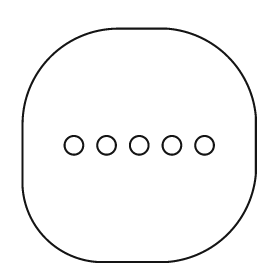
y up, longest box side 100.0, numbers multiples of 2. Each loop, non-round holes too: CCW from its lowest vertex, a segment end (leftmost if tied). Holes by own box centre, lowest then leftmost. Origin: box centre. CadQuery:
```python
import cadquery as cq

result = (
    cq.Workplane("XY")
    .moveTo(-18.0, -50.0)
    .lineTo(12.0, -50.0)
    .threePointArc((38.0, -38.0), (50.0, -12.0))
    .lineTo(50.0, 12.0)
    .threePointArc((38.0, 38.0), (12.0, 50.0))
    .lineTo(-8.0, 50.0)
    .threePointArc((-38.0, 38.0), (-50.0, 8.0))
    .lineTo(-50.0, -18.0)
    .threePointArc((-40.0, -40.0), (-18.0, -50.0))
    .close()
    .moveTo(-28.0, 0.0)
    .circle(4.0)
    .moveTo(-14.0, 0.0)
    .circle(4.0)
    .moveTo(0.0, 0.0)
    .circle(4.0)
    .moveTo(14.0, 0.0)
    .circle(4.0)
    .moveTo(28.0, 0.0)
    .circle(4.0)
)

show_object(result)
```